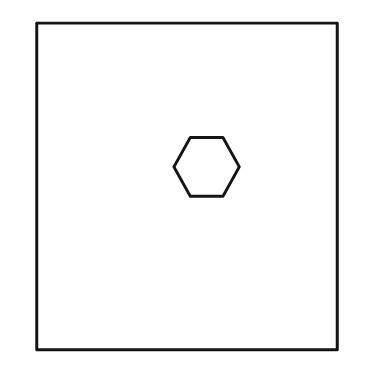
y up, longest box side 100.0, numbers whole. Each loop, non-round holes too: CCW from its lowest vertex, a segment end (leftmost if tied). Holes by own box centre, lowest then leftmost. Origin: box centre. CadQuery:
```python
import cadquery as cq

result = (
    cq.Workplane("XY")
    .moveTo(-46.0, -50.0)
    .lineTo(46.0, -50.0)
    .lineTo(46.0, 50.0)
    .lineTo(-46.0, 50.0)
    .close()
    .moveTo(1.0, -3.0)
    .lineTo(11.0, -3.0)
    .lineTo(16.0, 6.0)
    .lineTo(11.0, 15.0)
    .lineTo(1.0, 15.0)
    .lineTo(-4.0, 6.0)
    .close()
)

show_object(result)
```